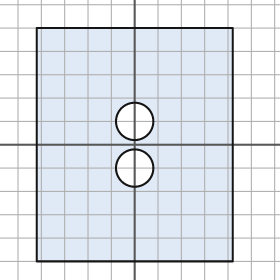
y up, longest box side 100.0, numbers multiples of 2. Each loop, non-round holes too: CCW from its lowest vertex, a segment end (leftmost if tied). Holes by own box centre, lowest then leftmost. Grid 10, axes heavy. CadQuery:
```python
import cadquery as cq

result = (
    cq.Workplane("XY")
    .moveTo(-42.0, -50.0)
    .lineTo(42.0, -50.0)
    .lineTo(42.0, 50.0)
    .lineTo(-42.0, 50.0)
    .close()
    .moveTo(0.0, -10.0)
    .circle(8.0)
    .moveTo(0.0, 10.0)
    .circle(8.0)
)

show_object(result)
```